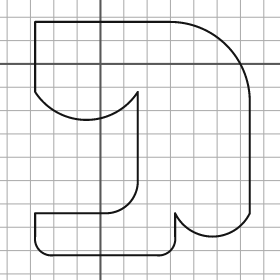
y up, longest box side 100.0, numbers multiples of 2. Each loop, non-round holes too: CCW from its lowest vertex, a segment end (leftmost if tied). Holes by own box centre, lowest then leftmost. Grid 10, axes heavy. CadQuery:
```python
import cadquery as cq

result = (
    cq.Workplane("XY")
    .moveTo(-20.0, -82.0)
    .lineTo(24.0, -82.0)
    .threePointArc((30.0, -80.0), (32.0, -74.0))
    .lineTo(32.0, -64.0)
    .threePointArc((48.0, -74.0), (64.0, -64.0))
    .lineTo(64.0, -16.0)
    .threePointArc((54.0, 8.0), (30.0, 18.0))
    .lineTo(-28.0, 18.0)
    .lineTo(-28.0, -12.0)
    .threePointArc((-6.0, -24.0), (16.0, -12.0))
    .lineTo(16.0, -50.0)
    .threePointArc((12.0, -60.0), (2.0, -64.0))
    .lineTo(-28.0, -64.0)
    .lineTo(-28.0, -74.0)
    .threePointArc((-26.0, -80.0), (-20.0, -82.0))
    .close()
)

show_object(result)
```